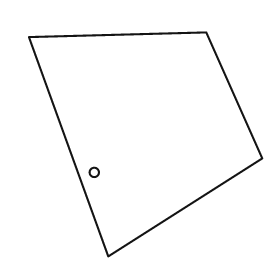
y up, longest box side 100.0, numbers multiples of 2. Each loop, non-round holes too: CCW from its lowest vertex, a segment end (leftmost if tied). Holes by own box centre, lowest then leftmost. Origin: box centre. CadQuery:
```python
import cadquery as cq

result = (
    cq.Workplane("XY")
    .moveTo(-16.0, -48.0)
    .lineTo(50.0, -6.0)
    .lineTo(26.0, 48.0)
    .lineTo(-50.0, 46.0)
    .close()
    .moveTo(-22.0, -12.0)
    .circle(2.0)
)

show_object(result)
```